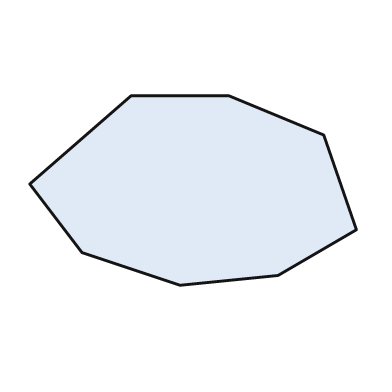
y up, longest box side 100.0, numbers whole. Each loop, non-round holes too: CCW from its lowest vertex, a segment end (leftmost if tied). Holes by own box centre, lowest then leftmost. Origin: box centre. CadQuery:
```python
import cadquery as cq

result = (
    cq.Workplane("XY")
    .moveTo(-4.0, -29.0)
    .lineTo(26.0, -26.0)
    .lineTo(50.0, -12.0)
    .lineTo(40.0, 17.0)
    .lineTo(11.0, 29.0)
    .lineTo(-19.0, 29.0)
    .lineTo(-50.0, 2.0)
    .lineTo(-34.0, -19.0)
    .close()
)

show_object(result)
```